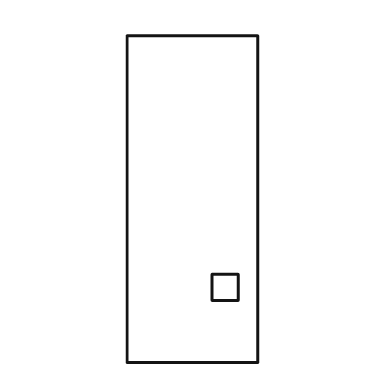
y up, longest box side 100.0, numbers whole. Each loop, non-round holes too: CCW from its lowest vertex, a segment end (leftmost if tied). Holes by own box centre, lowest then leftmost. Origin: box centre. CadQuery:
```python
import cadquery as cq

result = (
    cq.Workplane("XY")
    .moveTo(-20.0, -50.0)
    .lineTo(20.0, -50.0)
    .lineTo(20.0, 50.0)
    .lineTo(-20.0, 50.0)
    .close()
    .moveTo(6.0, -31.0)
    .lineTo(14.0, -31.0)
    .lineTo(14.0, -23.0)
    .lineTo(6.0, -23.0)
    .close()
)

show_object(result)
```